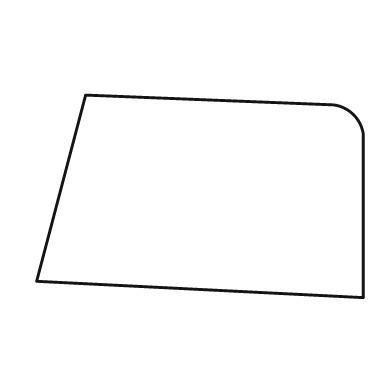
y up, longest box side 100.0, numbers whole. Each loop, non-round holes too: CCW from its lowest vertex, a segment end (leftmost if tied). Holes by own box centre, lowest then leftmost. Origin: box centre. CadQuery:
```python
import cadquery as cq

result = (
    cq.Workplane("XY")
    .moveTo(50.0, -31.0)
    .lineTo(50.0, 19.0)
    .threePointArc((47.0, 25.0), (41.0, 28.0))
    .lineTo(-35.0, 31.0)
    .lineTo(-50.0, -26.0)
    .close()
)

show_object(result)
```